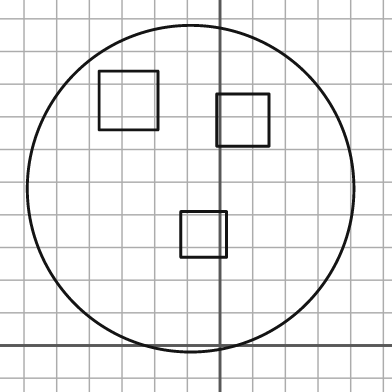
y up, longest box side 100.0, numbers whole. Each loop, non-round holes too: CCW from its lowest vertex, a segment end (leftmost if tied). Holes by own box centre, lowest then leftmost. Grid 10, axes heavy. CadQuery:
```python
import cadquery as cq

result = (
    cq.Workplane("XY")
    .moveTo(-9.0, 48.0)
    .circle(50.0)
    .moveTo(-12.0, 27.0)
    .lineTo(2.0, 27.0)
    .lineTo(2.0, 41.0)
    .lineTo(-12.0, 41.0)
    .close()
    .moveTo(-1.0, 61.0)
    .lineTo(15.0, 61.0)
    .lineTo(15.0, 77.0)
    .lineTo(-1.0, 77.0)
    .close()
    .moveTo(-37.0, 66.0)
    .lineTo(-19.0, 66.0)
    .lineTo(-19.0, 84.0)
    .lineTo(-37.0, 84.0)
    .close()
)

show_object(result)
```